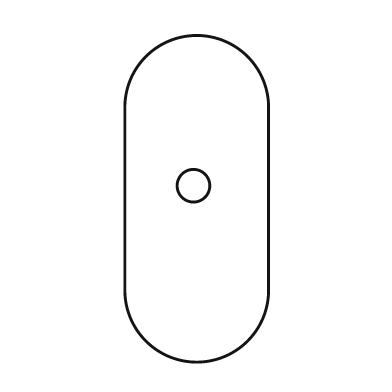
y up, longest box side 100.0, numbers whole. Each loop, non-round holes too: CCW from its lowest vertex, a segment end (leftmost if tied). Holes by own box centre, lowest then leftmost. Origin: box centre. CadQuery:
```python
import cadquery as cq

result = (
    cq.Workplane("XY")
    .moveTo(-22.0, -28.0)
    .threePointArc((0.0, -50.0), (22.0, -28.0))
    .lineTo(22.0, 28.0)
    .threePointArc((0.0, 50.0), (-22.0, 28.0))
    .close()
    .moveTo(-1.0, 4.0)
    .circle(5.0)
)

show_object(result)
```